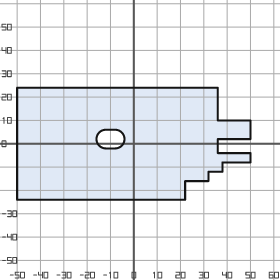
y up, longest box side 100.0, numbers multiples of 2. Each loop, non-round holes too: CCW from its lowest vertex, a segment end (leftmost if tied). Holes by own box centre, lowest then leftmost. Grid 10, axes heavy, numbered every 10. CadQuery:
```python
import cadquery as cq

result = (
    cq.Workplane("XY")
    .moveTo(-50.0, -24.0)
    .lineTo(22.0, -24.0)
    .lineTo(22.0, -16.0)
    .lineTo(32.0, -16.0)
    .lineTo(32.0, -12.0)
    .lineTo(38.0, -12.0)
    .lineTo(38.0, -8.0)
    .lineTo(50.0, -8.0)
    .lineTo(50.0, -4.0)
    .lineTo(36.0, -4.0)
    .lineTo(36.0, 2.0)
    .lineTo(50.0, 2.0)
    .lineTo(50.0, 10.0)
    .lineTo(36.0, 10.0)
    .lineTo(36.0, 24.0)
    .lineTo(-50.0, 24.0)
    .close()
    .moveTo(-12.0, -2.0)
    .lineTo(-8.0, -2.0)
    .threePointArc((-4.0, 2.0), (-8.0, 6.0))
    .lineTo(-12.0, 6.0)
    .threePointArc((-16.0, 2.0), (-12.0, -2.0))
    .close()
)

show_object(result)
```